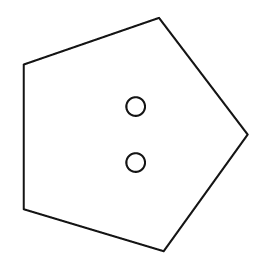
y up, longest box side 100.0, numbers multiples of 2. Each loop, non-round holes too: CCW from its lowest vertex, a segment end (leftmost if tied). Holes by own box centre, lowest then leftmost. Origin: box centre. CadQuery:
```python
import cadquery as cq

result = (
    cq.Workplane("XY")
    .moveTo(12.0, -50.0)
    .lineTo(48.0, 0.0)
    .lineTo(10.0, 50.0)
    .lineTo(-48.0, 30.0)
    .lineTo(-48.0, -32.0)
    .close()
    .moveTo(0.0, -12.0)
    .circle(4.0)
    .moveTo(0.0, 12.0)
    .circle(4.0)
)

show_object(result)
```